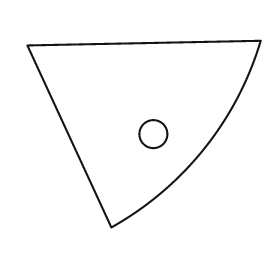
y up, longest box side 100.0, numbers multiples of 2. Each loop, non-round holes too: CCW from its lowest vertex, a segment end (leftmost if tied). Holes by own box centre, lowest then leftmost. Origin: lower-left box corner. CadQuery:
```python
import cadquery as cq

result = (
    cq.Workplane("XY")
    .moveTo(36.0, 0.0)
    .threePointArc((76.0, 34.0), (100.0, 80.0))
    .lineTo(0.0, 78.0)
    .close()
    .moveTo(54.0, 40.0)
    .circle(6.0)
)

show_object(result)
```